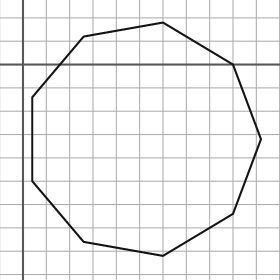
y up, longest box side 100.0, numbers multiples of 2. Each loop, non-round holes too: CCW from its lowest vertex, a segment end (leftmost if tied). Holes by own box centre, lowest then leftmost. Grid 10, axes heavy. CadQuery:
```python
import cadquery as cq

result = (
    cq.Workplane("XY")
    .moveTo(60.0, -82.0)
    .lineTo(90.0, -64.0)
    .lineTo(102.0, -32.0)
    .lineTo(90.0, 0.0)
    .lineTo(60.0, 18.0)
    .lineTo(26.0, 12.0)
    .lineTo(4.0, -14.0)
    .lineTo(4.0, -50.0)
    .lineTo(26.0, -76.0)
    .close()
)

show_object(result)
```